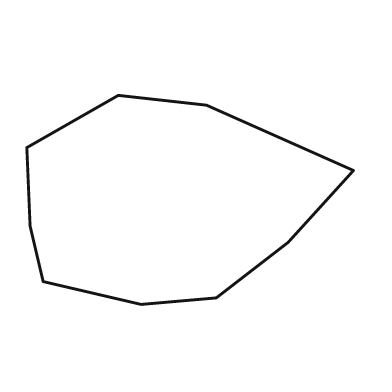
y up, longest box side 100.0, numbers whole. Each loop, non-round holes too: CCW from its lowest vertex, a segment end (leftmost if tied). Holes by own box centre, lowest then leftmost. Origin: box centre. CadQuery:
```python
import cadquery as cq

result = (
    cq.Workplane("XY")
    .moveTo(-15.0, -32.0)
    .lineTo(8.0, -30.0)
    .lineTo(30.0, -13.0)
    .lineTo(50.0, 9.0)
    .lineTo(5.0, 29.0)
    .lineTo(-22.0, 32.0)
    .lineTo(-50.0, 16.0)
    .lineTo(-49.0, -8.0)
    .lineTo(-45.0, -25.0)
    .close()
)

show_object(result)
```